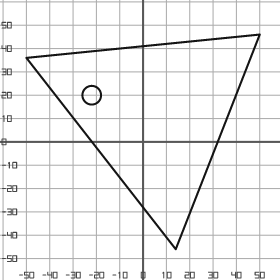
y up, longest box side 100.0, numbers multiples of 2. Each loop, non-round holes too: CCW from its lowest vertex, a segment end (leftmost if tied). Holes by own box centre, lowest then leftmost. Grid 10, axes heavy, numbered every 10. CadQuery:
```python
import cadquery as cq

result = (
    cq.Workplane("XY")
    .moveTo(14.0, -46.0)
    .lineTo(50.0, 46.0)
    .lineTo(-50.0, 36.0)
    .close()
    .moveTo(-22.0, 20.0)
    .circle(4.0)
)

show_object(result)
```